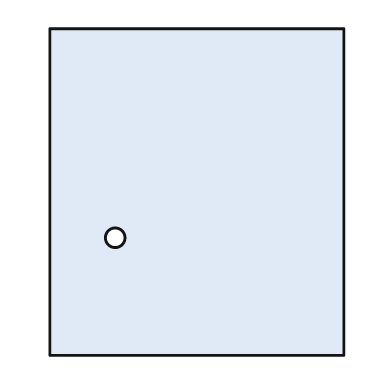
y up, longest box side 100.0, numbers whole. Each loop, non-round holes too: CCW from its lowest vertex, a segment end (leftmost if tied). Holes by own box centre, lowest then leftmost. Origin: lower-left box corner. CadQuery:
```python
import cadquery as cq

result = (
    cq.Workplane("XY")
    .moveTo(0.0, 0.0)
    .lineTo(90.0, 0.0)
    .lineTo(90.0, 100.0)
    .lineTo(0.0, 100.0)
    .close()
    .moveTo(20.0, 36.0)
    .circle(3.0)
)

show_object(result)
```